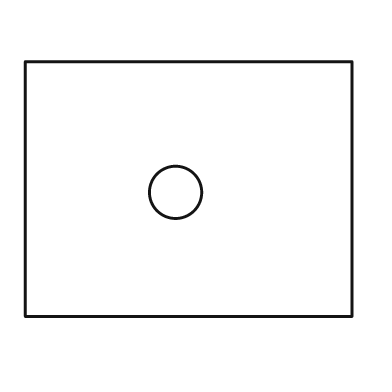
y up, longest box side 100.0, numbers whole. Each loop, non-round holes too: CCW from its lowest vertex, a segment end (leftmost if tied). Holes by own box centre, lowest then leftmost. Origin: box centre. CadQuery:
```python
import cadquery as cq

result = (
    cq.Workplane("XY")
    .moveTo(-50.0, -39.0)
    .lineTo(50.0, -39.0)
    .lineTo(50.0, 39.0)
    .lineTo(-50.0, 39.0)
    .close()
    .moveTo(-4.0, -1.0)
    .circle(8.0)
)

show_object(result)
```